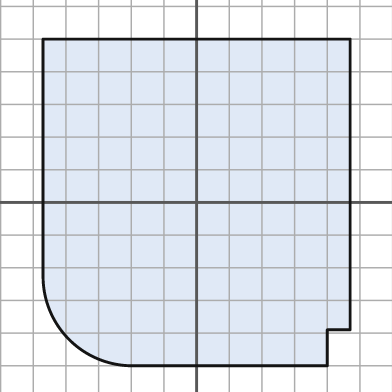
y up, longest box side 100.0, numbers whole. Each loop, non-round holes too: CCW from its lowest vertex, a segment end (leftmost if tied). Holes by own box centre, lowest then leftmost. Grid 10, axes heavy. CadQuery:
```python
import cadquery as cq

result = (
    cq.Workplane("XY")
    .moveTo(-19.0, -50.0)
    .lineTo(40.0, -50.0)
    .lineTo(40.0, -39.0)
    .lineTo(47.0, -39.0)
    .lineTo(47.0, 50.0)
    .lineTo(-47.0, 50.0)
    .lineTo(-47.0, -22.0)
    .threePointArc((-39.0, -42.0), (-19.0, -50.0))
    .close()
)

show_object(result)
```